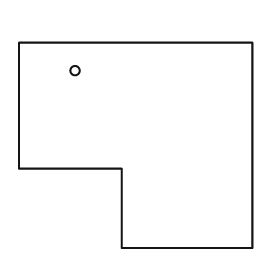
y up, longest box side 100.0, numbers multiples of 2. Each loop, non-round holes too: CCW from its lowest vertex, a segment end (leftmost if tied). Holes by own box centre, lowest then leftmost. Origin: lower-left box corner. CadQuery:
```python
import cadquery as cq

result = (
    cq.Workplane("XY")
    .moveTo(44.0, 0.0)
    .lineTo(100.0, 0.0)
    .lineTo(100.0, 88.0)
    .lineTo(0.0, 88.0)
    .lineTo(0.0, 34.0)
    .lineTo(44.0, 34.0)
    .close()
    .moveTo(24.0, 76.0)
    .circle(2.0)
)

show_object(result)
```